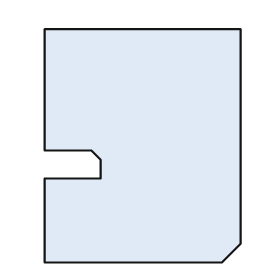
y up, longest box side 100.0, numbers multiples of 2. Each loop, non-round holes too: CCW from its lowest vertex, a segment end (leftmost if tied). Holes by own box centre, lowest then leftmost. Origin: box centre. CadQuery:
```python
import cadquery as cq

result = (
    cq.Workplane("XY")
    .moveTo(-42.0, -50.0)
    .lineTo(34.0, -50.0)
    .lineTo(42.0, -42.0)
    .lineTo(42.0, 50.0)
    .lineTo(-42.0, 50.0)
    .lineTo(-42.0, -2.0)
    .lineTo(-22.0, -2.0)
    .lineTo(-18.0, -6.0)
    .lineTo(-18.0, -14.0)
    .lineTo(-42.0, -14.0)
    .close()
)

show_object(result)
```